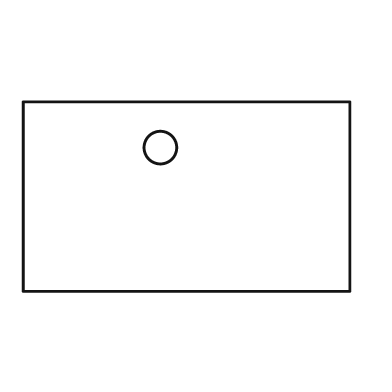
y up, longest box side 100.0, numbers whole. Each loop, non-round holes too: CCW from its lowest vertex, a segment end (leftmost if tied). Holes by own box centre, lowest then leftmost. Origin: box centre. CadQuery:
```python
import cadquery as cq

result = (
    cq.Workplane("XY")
    .moveTo(-50.0, -29.0)
    .lineTo(50.0, -29.0)
    .lineTo(50.0, 29.0)
    .lineTo(-50.0, 29.0)
    .close()
    .moveTo(-8.0, 15.0)
    .circle(5.0)
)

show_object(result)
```